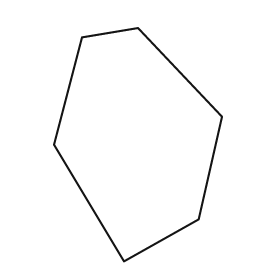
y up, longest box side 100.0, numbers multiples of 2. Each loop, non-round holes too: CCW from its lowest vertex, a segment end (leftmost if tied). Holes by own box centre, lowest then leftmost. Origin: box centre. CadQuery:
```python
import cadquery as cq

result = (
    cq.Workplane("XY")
    .moveTo(-6.0, -50.0)
    .lineTo(26.0, -32.0)
    .lineTo(36.0, 12.0)
    .lineTo(0.0, 50.0)
    .lineTo(-24.0, 46.0)
    .lineTo(-36.0, 0.0)
    .close()
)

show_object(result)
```